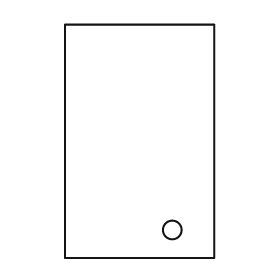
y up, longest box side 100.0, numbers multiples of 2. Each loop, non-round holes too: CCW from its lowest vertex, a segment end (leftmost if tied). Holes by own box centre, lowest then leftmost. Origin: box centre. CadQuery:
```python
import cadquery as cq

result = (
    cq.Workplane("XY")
    .moveTo(-32.0, -50.0)
    .lineTo(32.0, -50.0)
    .lineTo(32.0, 50.0)
    .lineTo(-32.0, 50.0)
    .close()
    .moveTo(14.0, -38.0)
    .circle(4.0)
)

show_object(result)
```